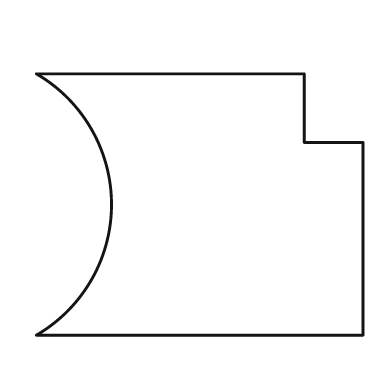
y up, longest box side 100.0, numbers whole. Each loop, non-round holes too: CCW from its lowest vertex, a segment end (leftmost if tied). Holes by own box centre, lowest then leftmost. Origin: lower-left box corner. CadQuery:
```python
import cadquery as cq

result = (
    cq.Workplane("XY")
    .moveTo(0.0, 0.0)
    .lineTo(100.0, 0.0)
    .lineTo(100.0, 59.0)
    .lineTo(82.0, 59.0)
    .lineTo(82.0, 80.0)
    .lineTo(0.0, 80.0)
    .threePointArc((23.0, 40.0), (0.0, 0.0))
    .close()
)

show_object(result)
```